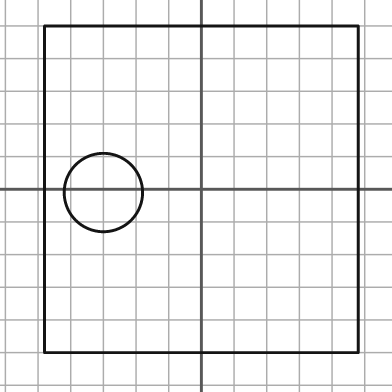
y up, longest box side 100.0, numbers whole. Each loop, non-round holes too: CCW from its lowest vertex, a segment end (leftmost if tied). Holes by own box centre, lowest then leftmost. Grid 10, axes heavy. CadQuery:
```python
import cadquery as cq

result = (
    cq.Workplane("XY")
    .moveTo(-48.0, -50.0)
    .lineTo(48.0, -50.0)
    .lineTo(48.0, 50.0)
    .lineTo(-48.0, 50.0)
    .close()
    .moveTo(-30.0, -1.0)
    .circle(12.0)
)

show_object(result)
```